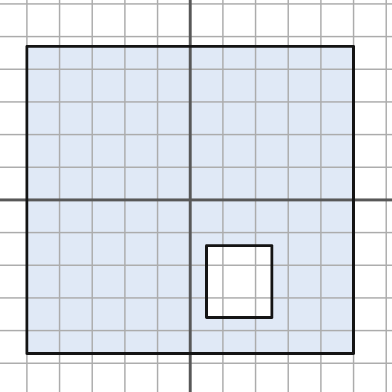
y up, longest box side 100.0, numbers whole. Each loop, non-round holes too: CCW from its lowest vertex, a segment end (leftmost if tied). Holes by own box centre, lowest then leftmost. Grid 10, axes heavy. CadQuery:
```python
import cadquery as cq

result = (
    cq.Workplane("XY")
    .moveTo(-50.0, -47.0)
    .lineTo(50.0, -47.0)
    .lineTo(50.0, 47.0)
    .lineTo(-50.0, 47.0)
    .close()
    .moveTo(5.0, -36.0)
    .lineTo(25.0, -36.0)
    .lineTo(25.0, -14.0)
    .lineTo(5.0, -14.0)
    .close()
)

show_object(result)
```